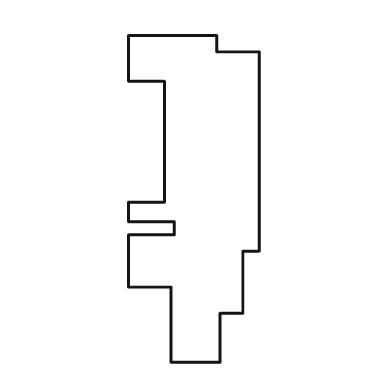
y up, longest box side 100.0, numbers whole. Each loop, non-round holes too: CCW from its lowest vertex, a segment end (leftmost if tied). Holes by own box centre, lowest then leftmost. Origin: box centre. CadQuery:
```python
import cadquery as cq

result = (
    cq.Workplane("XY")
    .moveTo(-7.0, -50.0)
    .lineTo(8.0, -50.0)
    .lineTo(8.0, -35.0)
    .lineTo(15.0, -35.0)
    .lineTo(15.0, -16.0)
    .lineTo(20.0, -16.0)
    .lineTo(20.0, 45.0)
    .lineTo(7.0, 45.0)
    .lineTo(7.0, 50.0)
    .lineTo(-20.0, 50.0)
    .lineTo(-20.0, 36.0)
    .lineTo(-9.0, 36.0)
    .lineTo(-9.0, -1.0)
    .lineTo(-20.0, -1.0)
    .lineTo(-20.0, -7.0)
    .lineTo(-6.0, -7.0)
    .lineTo(-6.0, -11.0)
    .lineTo(-20.0, -11.0)
    .lineTo(-20.0, -27.0)
    .lineTo(-7.0, -27.0)
    .close()
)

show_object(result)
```